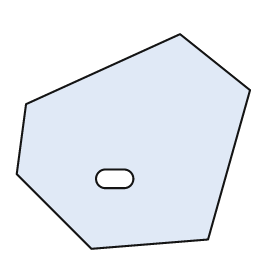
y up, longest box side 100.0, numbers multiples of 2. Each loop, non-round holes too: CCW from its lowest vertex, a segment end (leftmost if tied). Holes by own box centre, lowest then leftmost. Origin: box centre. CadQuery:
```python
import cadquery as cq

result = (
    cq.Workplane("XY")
    .moveTo(-18.0, -46.0)
    .lineTo(32.0, -42.0)
    .lineTo(50.0, 22.0)
    .lineTo(20.0, 46.0)
    .lineTo(-46.0, 16.0)
    .lineTo(-50.0, -14.0)
    .close()
    .moveTo(-12.0, -20.0)
    .lineTo(-4.0, -20.0)
    .threePointArc((0.0, -16.0), (-4.0, -12.0))
    .lineTo(-12.0, -12.0)
    .threePointArc((-16.0, -16.0), (-12.0, -20.0))
    .close()
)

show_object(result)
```